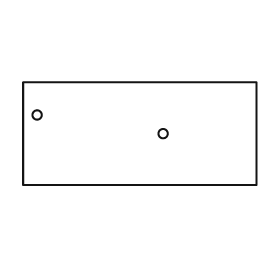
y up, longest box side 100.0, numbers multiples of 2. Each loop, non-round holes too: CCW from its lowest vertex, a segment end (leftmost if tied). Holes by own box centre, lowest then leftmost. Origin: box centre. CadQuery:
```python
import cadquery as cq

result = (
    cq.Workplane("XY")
    .moveTo(-50.0, -22.0)
    .lineTo(50.0, -22.0)
    .lineTo(50.0, 22.0)
    .lineTo(-50.0, 22.0)
    .close()
    .moveTo(10.0, 0.0)
    .circle(2.0)
    .moveTo(-44.0, 8.0)
    .circle(2.0)
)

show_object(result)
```